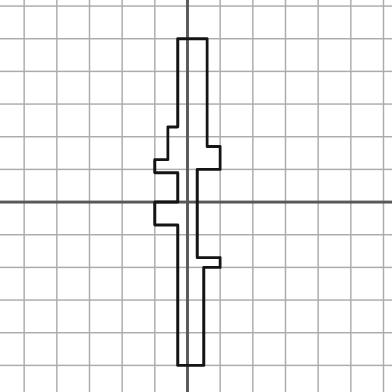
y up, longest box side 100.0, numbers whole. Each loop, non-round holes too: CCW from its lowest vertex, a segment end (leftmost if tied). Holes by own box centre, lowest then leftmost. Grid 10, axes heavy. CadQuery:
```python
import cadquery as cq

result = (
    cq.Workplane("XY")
    .moveTo(-3.0, -50.0)
    .lineTo(5.0, -50.0)
    .lineTo(5.0, -20.0)
    .lineTo(10.0, -20.0)
    .lineTo(10.0, -17.0)
    .lineTo(3.0, -17.0)
    .lineTo(3.0, 10.0)
    .lineTo(10.0, 10.0)
    .lineTo(10.0, 17.0)
    .lineTo(6.0, 17.0)
    .lineTo(6.0, 50.0)
    .lineTo(-3.0, 50.0)
    .lineTo(-3.0, 23.0)
    .lineTo(-6.0, 23.0)
    .lineTo(-6.0, 13.0)
    .lineTo(-10.0, 13.0)
    .lineTo(-10.0, 9.0)
    .lineTo(-3.0, 9.0)
    .lineTo(-3.0, 0.0)
    .lineTo(-10.0, 0.0)
    .lineTo(-10.0, -7.0)
    .lineTo(-3.0, -7.0)
    .close()
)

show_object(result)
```